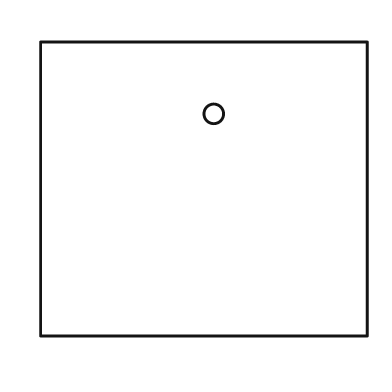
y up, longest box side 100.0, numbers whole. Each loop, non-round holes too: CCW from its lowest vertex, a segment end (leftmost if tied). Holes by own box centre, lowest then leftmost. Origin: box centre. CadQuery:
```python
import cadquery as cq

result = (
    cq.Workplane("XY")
    .moveTo(-50.0, -45.0)
    .lineTo(50.0, -45.0)
    .lineTo(50.0, 45.0)
    .lineTo(-50.0, 45.0)
    .close()
    .moveTo(3.0, 23.0)
    .circle(3.0)
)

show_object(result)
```